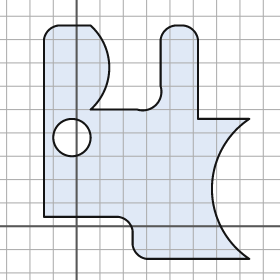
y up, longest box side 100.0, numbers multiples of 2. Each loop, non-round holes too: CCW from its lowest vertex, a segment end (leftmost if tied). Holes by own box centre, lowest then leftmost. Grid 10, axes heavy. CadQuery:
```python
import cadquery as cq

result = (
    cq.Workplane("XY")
    .moveTo(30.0, -14.0)
    .lineTo(74.0, -14.0)
    .threePointArc((58.0, 16.0), (74.0, 46.0))
    .lineTo(52.0, 46.0)
    .lineTo(52.0, 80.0)
    .threePointArc((50.0, 84.0), (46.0, 86.0))
    .lineTo(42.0, 86.0)
    .threePointArc((38.0, 84.0), (36.0, 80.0))
    .lineTo(36.0, 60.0)
    .threePointArc((34.0, 52.0), (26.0, 50.0))
    .lineTo(6.0, 50.0)
    .threePointArc((14.0, 68.0), (6.0, 86.0))
    .lineTo(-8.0, 86.0)
    .threePointArc((-12.0, 84.0), (-14.0, 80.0))
    .lineTo(-14.0, 4.0)
    .lineTo(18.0, 4.0)
    .threePointArc((22.0, 2.0), (24.0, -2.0))
    .lineTo(24.0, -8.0)
    .threePointArc((26.0, -12.0), (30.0, -14.0))
    .close()
    .moveTo(-2.0, 38.0)
    .circle(8.0)
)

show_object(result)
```